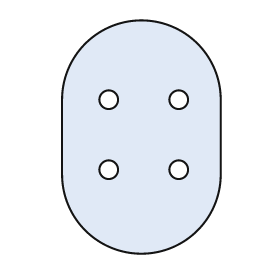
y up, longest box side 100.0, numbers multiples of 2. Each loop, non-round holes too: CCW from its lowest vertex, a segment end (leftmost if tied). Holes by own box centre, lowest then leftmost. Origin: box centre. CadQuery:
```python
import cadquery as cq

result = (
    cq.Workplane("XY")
    .moveTo(-34.0, -16.0)
    .threePointArc((0.0, -50.0), (34.0, -16.0))
    .lineTo(34.0, 16.0)
    .threePointArc((0.0, 50.0), (-34.0, 16.0))
    .close()
    .moveTo(-14.0, -14.0)
    .circle(4.0)
    .moveTo(16.0, -14.0)
    .circle(4.0)
    .moveTo(-14.0, 16.0)
    .circle(4.0)
    .moveTo(16.0, 16.0)
    .circle(4.0)
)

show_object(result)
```